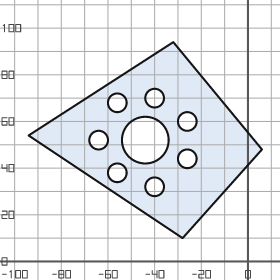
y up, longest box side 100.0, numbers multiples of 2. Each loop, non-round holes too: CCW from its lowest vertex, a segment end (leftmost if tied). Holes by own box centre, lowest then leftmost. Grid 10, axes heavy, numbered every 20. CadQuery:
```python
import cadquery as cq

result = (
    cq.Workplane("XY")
    .moveTo(-28.0, 10.0)
    .lineTo(6.0, 48.0)
    .lineTo(-32.0, 94.0)
    .lineTo(-94.0, 54.0)
    .close()
    .moveTo(-40.0, 32.0)
    .circle(4.0)
    .moveTo(-56.0, 38.0)
    .circle(4.0)
    .moveTo(-26.0, 44.0)
    .circle(4.0)
    .moveTo(-64.0, 52.0)
    .circle(4.0)
    .moveTo(-44.0, 52.0)
    .circle(10.0)
    .moveTo(-26.0, 60.0)
    .circle(4.0)
    .moveTo(-56.0, 68.0)
    .circle(4.0)
    .moveTo(-40.0, 70.0)
    .circle(4.0)
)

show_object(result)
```